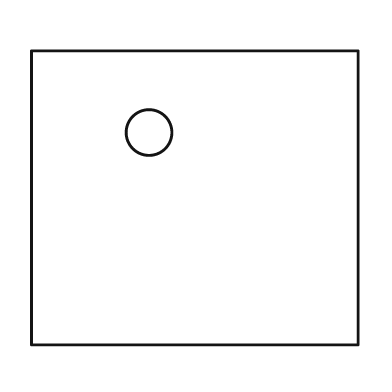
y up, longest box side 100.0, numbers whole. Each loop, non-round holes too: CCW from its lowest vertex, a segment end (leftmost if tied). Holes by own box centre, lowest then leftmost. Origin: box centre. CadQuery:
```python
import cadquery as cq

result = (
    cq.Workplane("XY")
    .moveTo(-50.0, -45.0)
    .lineTo(50.0, -45.0)
    .lineTo(50.0, 45.0)
    .lineTo(-50.0, 45.0)
    .close()
    .moveTo(-14.0, 20.0)
    .circle(7.0)
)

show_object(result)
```